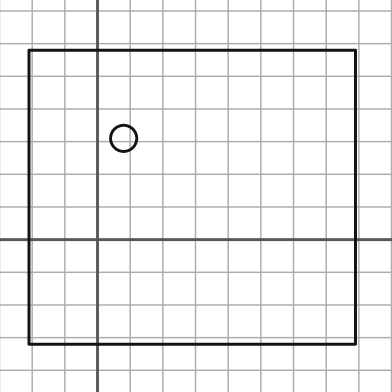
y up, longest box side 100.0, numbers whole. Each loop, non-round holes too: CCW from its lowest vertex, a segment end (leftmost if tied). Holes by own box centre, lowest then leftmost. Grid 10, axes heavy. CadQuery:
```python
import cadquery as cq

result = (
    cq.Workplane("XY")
    .moveTo(-21.0, -32.0)
    .lineTo(79.0, -32.0)
    .lineTo(79.0, 58.0)
    .lineTo(-21.0, 58.0)
    .close()
    .moveTo(8.0, 31.0)
    .circle(4.0)
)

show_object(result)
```